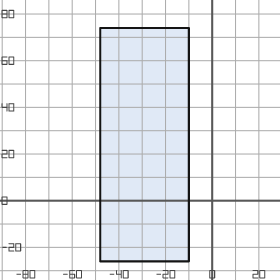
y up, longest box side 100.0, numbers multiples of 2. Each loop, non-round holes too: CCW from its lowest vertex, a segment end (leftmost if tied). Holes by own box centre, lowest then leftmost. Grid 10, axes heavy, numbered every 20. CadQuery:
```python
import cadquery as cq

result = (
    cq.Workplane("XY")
    .moveTo(-48.0, -26.0)
    .lineTo(-10.0, -26.0)
    .lineTo(-10.0, 74.0)
    .lineTo(-48.0, 74.0)
    .close()
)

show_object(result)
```